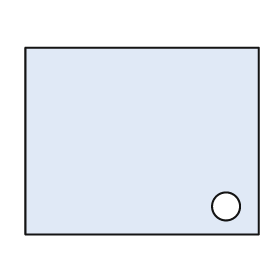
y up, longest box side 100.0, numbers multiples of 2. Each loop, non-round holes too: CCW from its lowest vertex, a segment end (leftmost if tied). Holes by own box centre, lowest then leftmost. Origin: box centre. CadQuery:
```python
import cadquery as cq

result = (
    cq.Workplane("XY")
    .moveTo(-50.0, -40.0)
    .lineTo(50.0, -40.0)
    .lineTo(50.0, 40.0)
    .lineTo(-50.0, 40.0)
    .close()
    .moveTo(36.0, -28.0)
    .circle(6.0)
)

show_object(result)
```